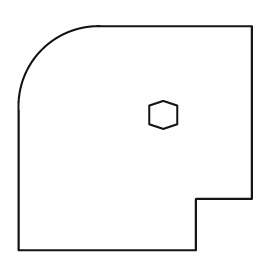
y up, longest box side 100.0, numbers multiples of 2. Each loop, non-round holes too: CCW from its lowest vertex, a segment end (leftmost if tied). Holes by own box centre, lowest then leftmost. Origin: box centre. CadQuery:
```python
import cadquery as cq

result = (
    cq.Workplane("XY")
    .moveTo(-50.0, -48.0)
    .lineTo(26.0, -48.0)
    .lineTo(26.0, -26.0)
    .lineTo(50.0, -26.0)
    .lineTo(50.0, 48.0)
    .lineTo(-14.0, 48.0)
    .threePointArc((-40.0, 38.0), (-50.0, 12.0))
    .close()
    .moveTo(12.0, 4.0)
    .lineTo(18.0, 6.0)
    .lineTo(18.0, 14.0)
    .lineTo(12.0, 16.0)
    .lineTo(6.0, 14.0)
    .lineTo(6.0, 6.0)
    .close()
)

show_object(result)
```